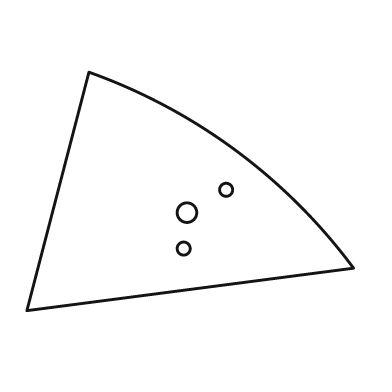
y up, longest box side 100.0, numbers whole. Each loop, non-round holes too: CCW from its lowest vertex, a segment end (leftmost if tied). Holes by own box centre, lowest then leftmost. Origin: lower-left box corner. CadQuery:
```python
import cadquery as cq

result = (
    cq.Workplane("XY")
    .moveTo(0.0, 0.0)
    .lineTo(100.0, 13.0)
    .threePointArc((64.0, 49.0), (19.0, 73.0))
    .close()
    .moveTo(48.0, 19.0)
    .circle(2.0)
    .moveTo(49.0, 30.0)
    .circle(3.0)
    .moveTo(61.0, 37.0)
    .circle(2.0)
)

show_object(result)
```